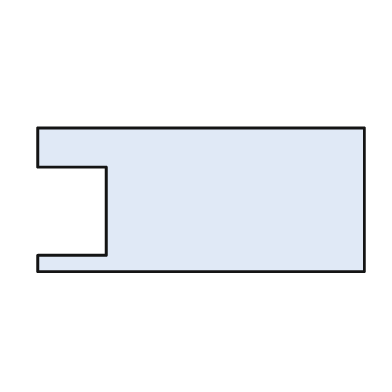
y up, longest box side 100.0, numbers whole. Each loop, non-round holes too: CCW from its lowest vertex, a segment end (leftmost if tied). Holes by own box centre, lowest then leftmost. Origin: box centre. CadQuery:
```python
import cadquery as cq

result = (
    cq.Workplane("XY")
    .moveTo(-50.0, -22.0)
    .lineTo(50.0, -22.0)
    .lineTo(50.0, 22.0)
    .lineTo(-50.0, 22.0)
    .lineTo(-50.0, 10.0)
    .lineTo(-29.0, 10.0)
    .lineTo(-29.0, -17.0)
    .lineTo(-50.0, -17.0)
    .close()
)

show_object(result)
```